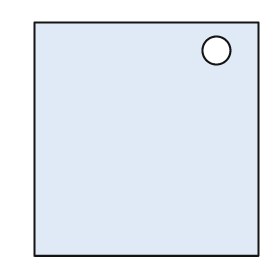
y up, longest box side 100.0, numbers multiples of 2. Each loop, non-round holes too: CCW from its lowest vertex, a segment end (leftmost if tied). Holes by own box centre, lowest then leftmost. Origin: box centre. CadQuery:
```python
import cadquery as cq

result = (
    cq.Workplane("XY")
    .moveTo(-48.0, -50.0)
    .lineTo(48.0, -50.0)
    .lineTo(48.0, 50.0)
    .lineTo(-48.0, 50.0)
    .close()
    .moveTo(30.0, 38.0)
    .circle(6.0)
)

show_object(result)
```